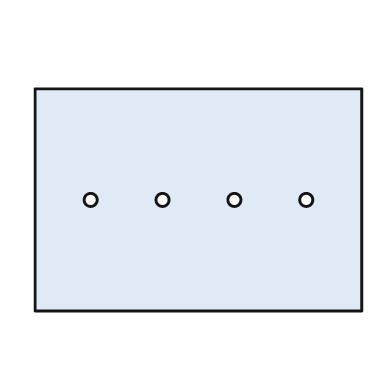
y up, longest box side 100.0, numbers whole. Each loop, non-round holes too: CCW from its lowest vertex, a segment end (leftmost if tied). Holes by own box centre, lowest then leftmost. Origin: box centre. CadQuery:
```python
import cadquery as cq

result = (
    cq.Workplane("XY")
    .moveTo(-50.0, -34.0)
    .lineTo(50.0, -34.0)
    .lineTo(50.0, 34.0)
    .lineTo(-50.0, 34.0)
    .close()
    .moveTo(-33.0, 0.0)
    .circle(2.0)
    .moveTo(-11.0, 0.0)
    .circle(2.0)
    .moveTo(11.0, 0.0)
    .circle(2.0)
    .moveTo(33.0, 0.0)
    .circle(2.0)
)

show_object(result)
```